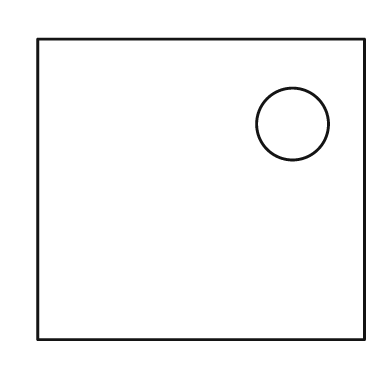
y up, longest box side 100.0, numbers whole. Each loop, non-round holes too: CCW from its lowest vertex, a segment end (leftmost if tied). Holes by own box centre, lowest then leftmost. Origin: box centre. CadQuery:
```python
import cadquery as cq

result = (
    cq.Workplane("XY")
    .moveTo(-50.0, -46.0)
    .lineTo(50.0, -46.0)
    .lineTo(50.0, 46.0)
    .lineTo(-50.0, 46.0)
    .close()
    .moveTo(28.0, 20.0)
    .circle(11.0)
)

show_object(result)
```